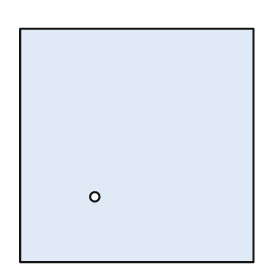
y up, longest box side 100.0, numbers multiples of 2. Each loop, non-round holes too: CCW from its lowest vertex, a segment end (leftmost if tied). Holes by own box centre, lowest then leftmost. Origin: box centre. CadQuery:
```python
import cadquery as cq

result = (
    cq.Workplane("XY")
    .moveTo(-50.0, -50.0)
    .lineTo(50.0, -50.0)
    .lineTo(50.0, 50.0)
    .lineTo(-50.0, 50.0)
    .close()
    .moveTo(-18.0, -22.0)
    .circle(2.0)
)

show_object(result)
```